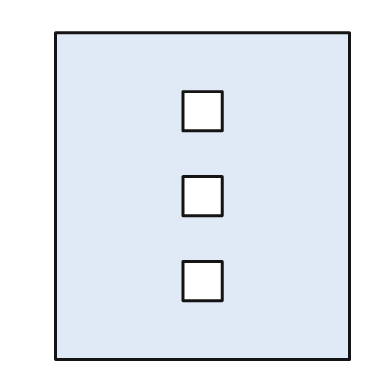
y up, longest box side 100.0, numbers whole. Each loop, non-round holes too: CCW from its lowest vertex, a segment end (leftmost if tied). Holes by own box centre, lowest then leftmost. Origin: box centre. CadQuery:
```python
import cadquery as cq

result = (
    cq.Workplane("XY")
    .moveTo(-45.0, -50.0)
    .lineTo(45.0, -50.0)
    .lineTo(45.0, 50.0)
    .lineTo(-45.0, 50.0)
    .close()
    .moveTo(-6.0, -32.0)
    .lineTo(6.0, -32.0)
    .lineTo(6.0, -20.0)
    .lineTo(-6.0, -20.0)
    .close()
    .moveTo(-6.0, -6.0)
    .lineTo(6.0, -6.0)
    .lineTo(6.0, 6.0)
    .lineTo(-6.0, 6.0)
    .close()
    .moveTo(-6.0, 20.0)
    .lineTo(6.0, 20.0)
    .lineTo(6.0, 32.0)
    .lineTo(-6.0, 32.0)
    .close()
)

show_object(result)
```